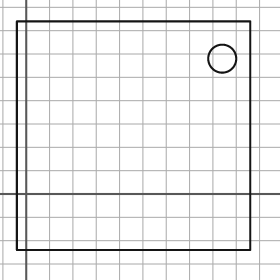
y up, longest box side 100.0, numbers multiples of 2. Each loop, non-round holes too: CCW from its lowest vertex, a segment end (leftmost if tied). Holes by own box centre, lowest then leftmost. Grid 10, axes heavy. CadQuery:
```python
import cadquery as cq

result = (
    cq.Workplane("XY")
    .moveTo(-4.0, -24.0)
    .lineTo(96.0, -24.0)
    .lineTo(96.0, 74.0)
    .lineTo(-4.0, 74.0)
    .close()
    .moveTo(84.0, 58.0)
    .circle(6.0)
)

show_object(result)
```